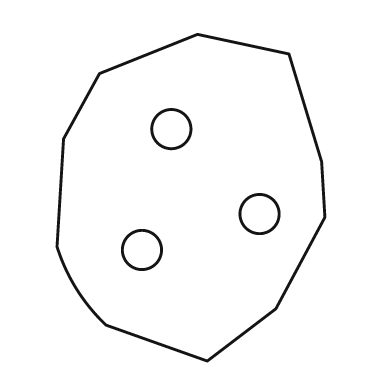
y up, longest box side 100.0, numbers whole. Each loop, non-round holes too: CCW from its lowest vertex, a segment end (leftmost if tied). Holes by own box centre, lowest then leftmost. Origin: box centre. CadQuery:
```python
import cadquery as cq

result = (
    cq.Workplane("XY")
    .moveTo(5.0, -50.0)
    .lineTo(26.0, -34.0)
    .lineTo(41.0, -6.0)
    .lineTo(40.0, 11.0)
    .lineTo(30.0, 44.0)
    .lineTo(2.0, 50.0)
    .lineTo(-28.0, 38.0)
    .lineTo(-39.0, 18.0)
    .lineTo(-41.0, -15.0)
    .threePointArc((-35.0, -28.0), (-26.0, -39.0))
    .close()
    .moveTo(-15.0, -16.0)
    .circle(6.0)
    .moveTo(21.0, -5.0)
    .circle(6.0)
    .moveTo(-6.0, 21.0)
    .circle(6.0)
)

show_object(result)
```